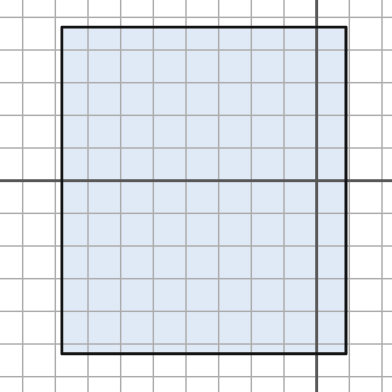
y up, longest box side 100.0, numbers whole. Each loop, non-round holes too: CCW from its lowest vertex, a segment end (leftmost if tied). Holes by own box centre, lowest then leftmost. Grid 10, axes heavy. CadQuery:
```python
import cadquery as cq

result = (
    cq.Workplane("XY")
    .moveTo(-78.0, -53.0)
    .lineTo(9.0, -53.0)
    .lineTo(9.0, 47.0)
    .lineTo(-78.0, 47.0)
    .close()
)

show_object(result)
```